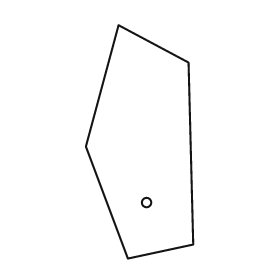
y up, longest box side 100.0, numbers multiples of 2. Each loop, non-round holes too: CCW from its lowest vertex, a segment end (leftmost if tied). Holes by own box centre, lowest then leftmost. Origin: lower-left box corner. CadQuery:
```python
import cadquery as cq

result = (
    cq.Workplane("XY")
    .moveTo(18.0, 0.0)
    .lineTo(46.0, 6.0)
    .lineTo(44.0, 84.0)
    .lineTo(14.0, 100.0)
    .lineTo(0.0, 48.0)
    .close()
    .moveTo(26.0, 24.0)
    .circle(2.0)
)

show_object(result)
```